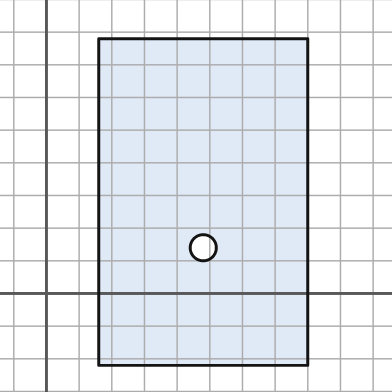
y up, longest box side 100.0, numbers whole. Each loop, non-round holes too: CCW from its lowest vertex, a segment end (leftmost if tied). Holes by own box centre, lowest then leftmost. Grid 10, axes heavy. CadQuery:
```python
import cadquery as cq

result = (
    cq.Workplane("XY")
    .moveTo(16.0, -22.0)
    .lineTo(80.0, -22.0)
    .lineTo(80.0, 78.0)
    .lineTo(16.0, 78.0)
    .close()
    .moveTo(48.0, 14.0)
    .circle(4.0)
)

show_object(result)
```